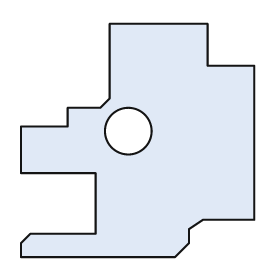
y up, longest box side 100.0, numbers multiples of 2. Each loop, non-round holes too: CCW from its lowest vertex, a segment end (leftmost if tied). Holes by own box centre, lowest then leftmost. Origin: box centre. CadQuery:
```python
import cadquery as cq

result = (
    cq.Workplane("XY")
    .moveTo(-50.0, -50.0)
    .lineTo(16.0, -50.0)
    .lineTo(22.0, -44.0)
    .lineTo(22.0, -38.0)
    .lineTo(28.0, -34.0)
    .lineTo(50.0, -34.0)
    .lineTo(50.0, 32.0)
    .lineTo(30.0, 32.0)
    .lineTo(30.0, 50.0)
    .lineTo(-12.0, 50.0)
    .lineTo(-12.0, 18.0)
    .lineTo(-16.0, 14.0)
    .lineTo(-30.0, 14.0)
    .lineTo(-30.0, 6.0)
    .lineTo(-50.0, 6.0)
    .lineTo(-50.0, -14.0)
    .lineTo(-18.0, -14.0)
    .lineTo(-18.0, -40.0)
    .lineTo(-46.0, -40.0)
    .lineTo(-50.0, -44.0)
    .close()
    .moveTo(-4.0, 4.0)
    .circle(10.0)
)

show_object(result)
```